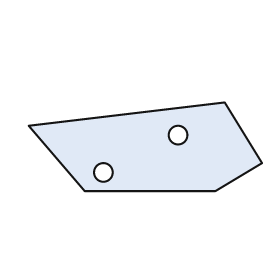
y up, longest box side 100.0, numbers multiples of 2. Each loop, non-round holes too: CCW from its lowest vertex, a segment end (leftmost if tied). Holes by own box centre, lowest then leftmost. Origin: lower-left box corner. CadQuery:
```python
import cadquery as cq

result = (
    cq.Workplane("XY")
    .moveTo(24.0, 0.0)
    .lineTo(80.0, 0.0)
    .lineTo(100.0, 12.0)
    .lineTo(84.0, 38.0)
    .lineTo(0.0, 28.0)
    .close()
    .moveTo(32.0, 8.0)
    .circle(4.0)
    .moveTo(64.0, 24.0)
    .circle(4.0)
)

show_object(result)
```